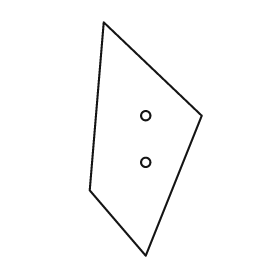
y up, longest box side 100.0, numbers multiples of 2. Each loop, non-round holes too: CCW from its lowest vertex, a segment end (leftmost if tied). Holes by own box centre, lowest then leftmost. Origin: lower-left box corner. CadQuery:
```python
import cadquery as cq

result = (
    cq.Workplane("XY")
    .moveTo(24.0, 0.0)
    .lineTo(48.0, 60.0)
    .lineTo(6.0, 100.0)
    .lineTo(0.0, 28.0)
    .close()
    .moveTo(24.0, 40.0)
    .circle(2.0)
    .moveTo(24.0, 60.0)
    .circle(2.0)
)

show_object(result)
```